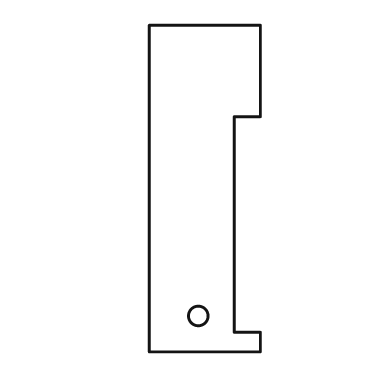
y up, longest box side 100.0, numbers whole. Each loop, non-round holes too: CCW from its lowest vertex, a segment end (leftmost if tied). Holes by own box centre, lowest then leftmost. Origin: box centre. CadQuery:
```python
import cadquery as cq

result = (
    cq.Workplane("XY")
    .moveTo(-17.0, -50.0)
    .lineTo(17.0, -50.0)
    .lineTo(17.0, -44.0)
    .lineTo(9.0, -44.0)
    .lineTo(9.0, 22.0)
    .lineTo(17.0, 22.0)
    .lineTo(17.0, 50.0)
    .lineTo(-17.0, 50.0)
    .close()
    .moveTo(-2.0, -39.0)
    .circle(3.0)
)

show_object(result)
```